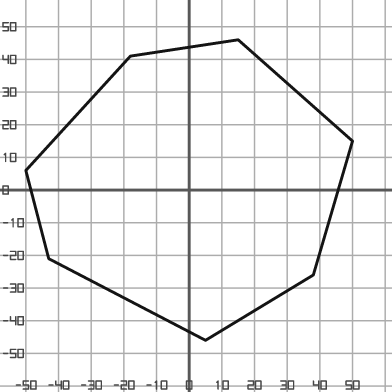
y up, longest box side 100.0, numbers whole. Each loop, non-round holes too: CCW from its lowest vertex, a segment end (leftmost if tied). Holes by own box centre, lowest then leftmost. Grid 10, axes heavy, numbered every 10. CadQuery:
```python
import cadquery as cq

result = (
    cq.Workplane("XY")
    .moveTo(5.0, -46.0)
    .lineTo(38.0, -26.0)
    .lineTo(50.0, 15.0)
    .lineTo(15.0, 46.0)
    .lineTo(-18.0, 41.0)
    .lineTo(-50.0, 6.0)
    .lineTo(-43.0, -21.0)
    .close()
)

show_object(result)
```